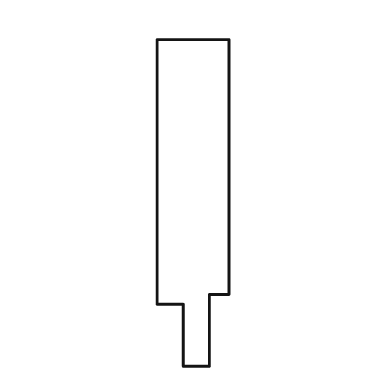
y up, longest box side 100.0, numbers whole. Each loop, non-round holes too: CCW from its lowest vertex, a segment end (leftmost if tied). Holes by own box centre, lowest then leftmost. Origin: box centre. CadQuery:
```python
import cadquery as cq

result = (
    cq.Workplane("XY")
    .moveTo(-3.0, -50.0)
    .lineTo(5.0, -50.0)
    .lineTo(5.0, -28.0)
    .lineTo(11.0, -28.0)
    .lineTo(11.0, 50.0)
    .lineTo(-11.0, 50.0)
    .lineTo(-11.0, -31.0)
    .lineTo(-3.0, -31.0)
    .close()
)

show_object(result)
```